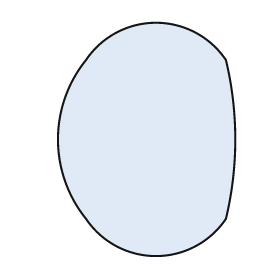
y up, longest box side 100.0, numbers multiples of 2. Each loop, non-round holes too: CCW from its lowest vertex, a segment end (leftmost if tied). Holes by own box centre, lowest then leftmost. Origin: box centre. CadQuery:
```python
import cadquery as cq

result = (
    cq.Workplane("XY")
    .moveTo(-26.0, -34.0)
    .threePointArc((4.0, -50.0), (34.0, -34.0))
    .threePointArc((38.0, 0.0), (34.0, 34.0))
    .threePointArc((4.0, 50.0), (-26.0, 34.0))
    .threePointArc((-38.0, 0.0), (-26.0, -34.0))
    .close()
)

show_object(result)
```